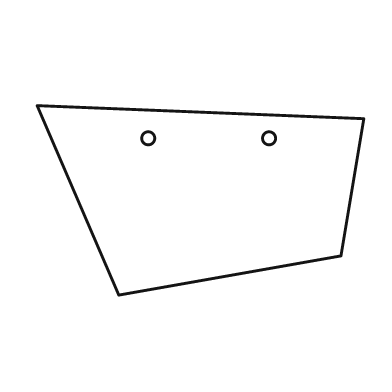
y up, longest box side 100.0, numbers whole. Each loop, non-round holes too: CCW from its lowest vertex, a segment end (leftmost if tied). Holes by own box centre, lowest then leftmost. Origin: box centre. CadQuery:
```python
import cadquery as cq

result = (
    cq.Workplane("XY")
    .moveTo(-25.0, -29.0)
    .lineTo(43.0, -17.0)
    .lineTo(50.0, 25.0)
    .lineTo(-50.0, 29.0)
    .close()
    .moveTo(-16.0, 19.0)
    .circle(2.0)
    .moveTo(21.0, 19.0)
    .circle(2.0)
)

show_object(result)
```